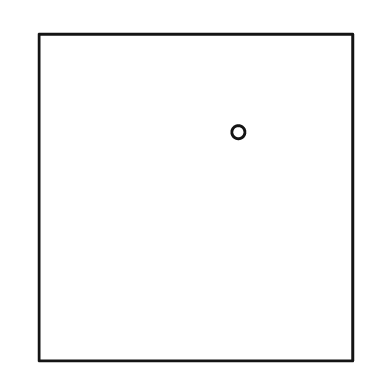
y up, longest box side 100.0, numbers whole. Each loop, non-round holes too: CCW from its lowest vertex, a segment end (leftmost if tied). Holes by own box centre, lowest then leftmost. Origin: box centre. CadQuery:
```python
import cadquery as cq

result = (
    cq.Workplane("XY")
    .moveTo(-48.0, -50.0)
    .lineTo(48.0, -50.0)
    .lineTo(48.0, 50.0)
    .lineTo(-48.0, 50.0)
    .close()
    .moveTo(13.0, 20.0)
    .circle(2.0)
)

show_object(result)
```